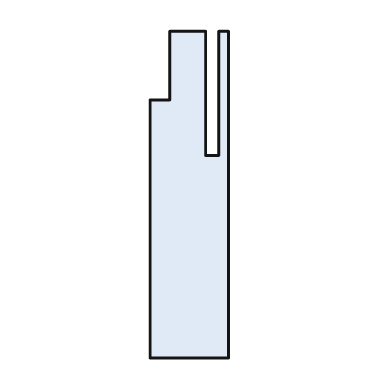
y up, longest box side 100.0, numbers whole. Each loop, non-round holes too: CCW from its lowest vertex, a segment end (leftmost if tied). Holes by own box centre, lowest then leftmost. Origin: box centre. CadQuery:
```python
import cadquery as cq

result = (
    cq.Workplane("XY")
    .moveTo(-12.0, -50.0)
    .lineTo(12.0, -50.0)
    .lineTo(12.0, 50.0)
    .lineTo(9.0, 50.0)
    .lineTo(9.0, 12.0)
    .lineTo(5.0, 12.0)
    .lineTo(5.0, 50.0)
    .lineTo(-6.0, 50.0)
    .lineTo(-6.0, 29.0)
    .lineTo(-12.0, 29.0)
    .close()
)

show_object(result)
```